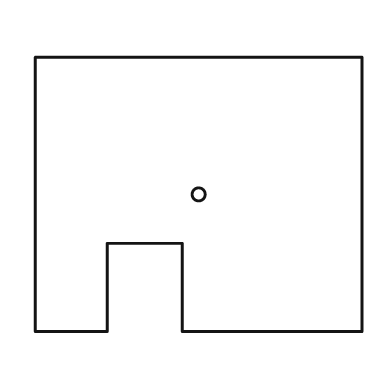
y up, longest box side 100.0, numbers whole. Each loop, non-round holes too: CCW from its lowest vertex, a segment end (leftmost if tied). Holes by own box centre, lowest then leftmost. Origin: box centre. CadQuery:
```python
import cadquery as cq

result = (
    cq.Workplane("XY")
    .moveTo(-50.0, -42.0)
    .lineTo(-28.0, -42.0)
    .lineTo(-28.0, -15.0)
    .lineTo(-5.0, -15.0)
    .lineTo(-5.0, -42.0)
    .lineTo(50.0, -42.0)
    .lineTo(50.0, 42.0)
    .lineTo(-50.0, 42.0)
    .close()
    .moveTo(0.0, 0.0)
    .circle(2.0)
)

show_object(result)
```